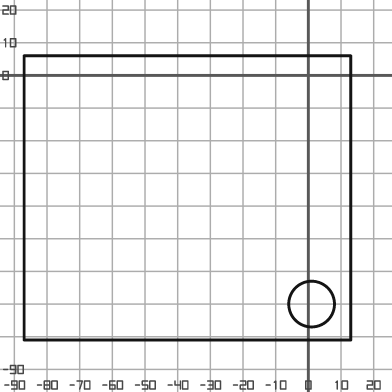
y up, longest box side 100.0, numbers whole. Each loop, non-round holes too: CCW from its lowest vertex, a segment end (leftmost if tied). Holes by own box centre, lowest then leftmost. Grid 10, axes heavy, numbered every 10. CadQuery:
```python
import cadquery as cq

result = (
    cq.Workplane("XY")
    .moveTo(-87.0, -81.0)
    .lineTo(13.0, -81.0)
    .lineTo(13.0, 6.0)
    .lineTo(-87.0, 6.0)
    .close()
    .moveTo(1.0, -70.0)
    .circle(7.0)
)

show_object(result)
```